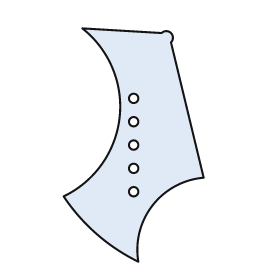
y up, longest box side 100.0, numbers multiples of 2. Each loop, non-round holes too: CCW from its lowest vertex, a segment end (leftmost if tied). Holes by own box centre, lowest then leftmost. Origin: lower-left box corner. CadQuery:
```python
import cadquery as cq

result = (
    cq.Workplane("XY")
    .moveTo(32.0, 0.0)
    .threePointArc((38.0, 24.0), (60.0, 36.0))
    .lineTo(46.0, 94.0)
    .threePointArc((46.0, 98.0), (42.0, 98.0))
    .lineTo(8.0, 100.0)
    .threePointArc((24.0, 62.0), (0.0, 28.0))
    .threePointArc((14.0, 12.0), (32.0, 0.0))
    .close()
    .moveTo(30.0, 30.0)
    .circle(2.0)
    .moveTo(30.0, 40.0)
    .circle(2.0)
    .moveTo(30.0, 50.0)
    .circle(2.0)
    .moveTo(30.0, 60.0)
    .circle(2.0)
    .moveTo(30.0, 70.0)
    .circle(2.0)
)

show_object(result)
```